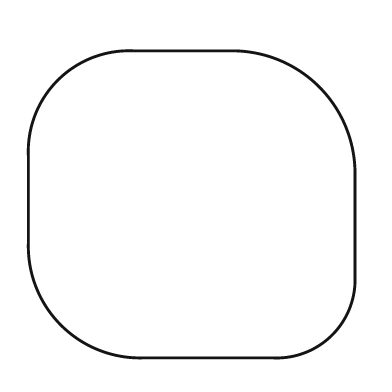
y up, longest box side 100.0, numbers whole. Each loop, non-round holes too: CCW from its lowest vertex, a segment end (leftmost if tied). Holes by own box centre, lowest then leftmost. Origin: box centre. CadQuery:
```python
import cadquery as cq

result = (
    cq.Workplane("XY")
    .moveTo(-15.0, -47.0)
    .lineTo(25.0, -47.0)
    .threePointArc((43.0, -40.0), (50.0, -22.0))
    .lineTo(50.0, 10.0)
    .threePointArc((39.0, 36.0), (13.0, 47.0))
    .lineTo(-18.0, 47.0)
    .threePointArc((-41.0, 38.0), (-50.0, 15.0))
    .lineTo(-50.0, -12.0)
    .threePointArc((-40.0, -37.0), (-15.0, -47.0))
    .close()
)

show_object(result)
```